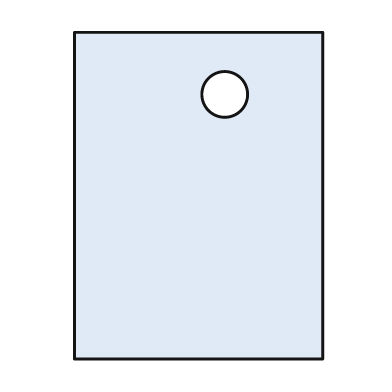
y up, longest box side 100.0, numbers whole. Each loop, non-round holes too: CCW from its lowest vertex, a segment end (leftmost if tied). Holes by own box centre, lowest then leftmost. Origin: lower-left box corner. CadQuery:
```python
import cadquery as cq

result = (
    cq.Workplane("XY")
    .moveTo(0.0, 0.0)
    .lineTo(76.0, 0.0)
    .lineTo(76.0, 100.0)
    .lineTo(0.0, 100.0)
    .close()
    .moveTo(46.0, 81.0)
    .circle(7.0)
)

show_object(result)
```